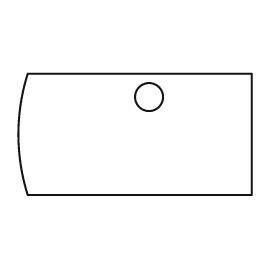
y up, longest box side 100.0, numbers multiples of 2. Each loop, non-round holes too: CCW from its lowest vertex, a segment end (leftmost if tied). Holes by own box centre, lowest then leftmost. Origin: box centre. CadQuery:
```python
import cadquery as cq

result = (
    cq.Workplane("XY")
    .moveTo(-46.0, -26.0)
    .lineTo(50.0, -26.0)
    .lineTo(50.0, 26.0)
    .lineTo(-46.0, 26.0)
    .threePointArc((-50.0, 0.0), (-46.0, -26.0))
    .close()
    .moveTo(6.0, 16.0)
    .circle(6.0)
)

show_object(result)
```